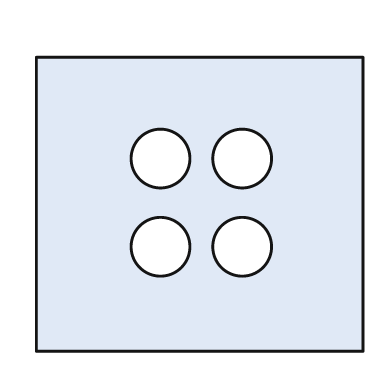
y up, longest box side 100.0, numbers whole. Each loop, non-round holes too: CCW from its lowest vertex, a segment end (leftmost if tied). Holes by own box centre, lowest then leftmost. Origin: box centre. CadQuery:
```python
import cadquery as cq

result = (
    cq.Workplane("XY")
    .moveTo(-50.0, -45.0)
    .lineTo(50.0, -45.0)
    .lineTo(50.0, 45.0)
    .lineTo(-50.0, 45.0)
    .close()
    .moveTo(-12.0, -13.0)
    .circle(9.0)
    .moveTo(13.0, -13.0)
    .circle(9.0)
    .moveTo(-12.0, 14.0)
    .circle(9.0)
    .moveTo(13.0, 14.0)
    .circle(9.0)
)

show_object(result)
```